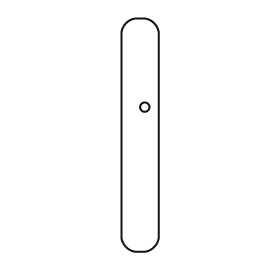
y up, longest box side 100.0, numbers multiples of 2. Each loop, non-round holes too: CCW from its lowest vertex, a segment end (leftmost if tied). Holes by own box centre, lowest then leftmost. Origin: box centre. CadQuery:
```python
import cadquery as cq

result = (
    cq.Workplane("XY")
    .moveTo(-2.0, -50.0)
    .lineTo(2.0, -50.0)
    .threePointArc((6.0, -48.0), (8.0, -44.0))
    .lineTo(8.0, 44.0)
    .threePointArc((6.0, 48.0), (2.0, 50.0))
    .lineTo(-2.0, 50.0)
    .threePointArc((-6.0, 48.0), (-8.0, 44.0))
    .lineTo(-8.0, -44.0)
    .threePointArc((-6.0, -48.0), (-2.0, -50.0))
    .close()
    .moveTo(2.0, 12.0)
    .circle(2.0)
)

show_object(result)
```